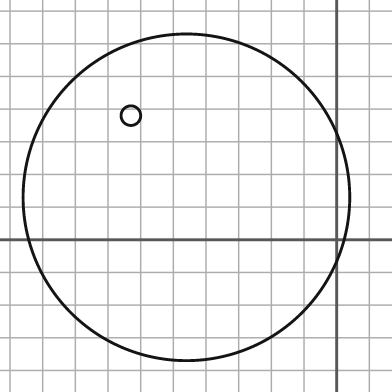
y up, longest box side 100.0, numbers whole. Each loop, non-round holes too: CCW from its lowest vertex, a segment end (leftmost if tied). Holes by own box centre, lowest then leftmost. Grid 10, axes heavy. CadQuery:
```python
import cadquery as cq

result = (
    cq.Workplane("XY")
    .moveTo(-46.0, 13.0)
    .circle(50.0)
    .moveTo(-63.0, 38.0)
    .circle(3.0)
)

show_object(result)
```